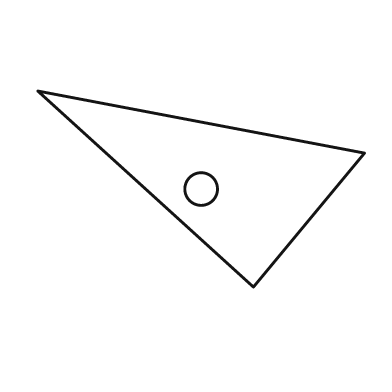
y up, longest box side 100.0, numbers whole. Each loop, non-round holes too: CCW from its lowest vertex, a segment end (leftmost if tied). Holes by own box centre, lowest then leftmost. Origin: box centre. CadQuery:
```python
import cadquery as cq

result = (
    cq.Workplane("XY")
    .moveTo(16.0, -30.0)
    .lineTo(50.0, 11.0)
    .lineTo(-50.0, 30.0)
    .close()
    .moveTo(0.0, 0.0)
    .circle(5.0)
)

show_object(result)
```